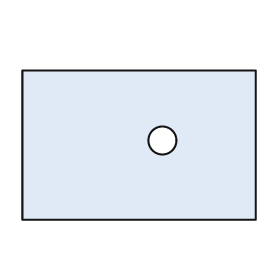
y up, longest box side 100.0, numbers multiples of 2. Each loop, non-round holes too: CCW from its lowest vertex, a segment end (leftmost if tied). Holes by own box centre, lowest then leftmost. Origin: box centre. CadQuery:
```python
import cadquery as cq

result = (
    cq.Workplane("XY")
    .moveTo(-50.0, -32.0)
    .lineTo(50.0, -32.0)
    .lineTo(50.0, 32.0)
    .lineTo(-50.0, 32.0)
    .close()
    .moveTo(10.0, 2.0)
    .circle(6.0)
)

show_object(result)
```